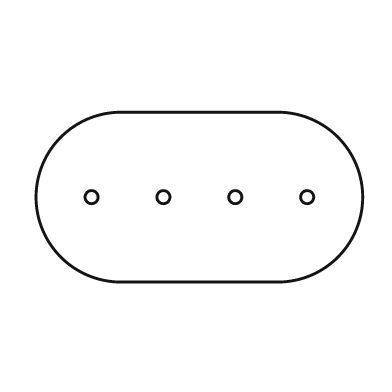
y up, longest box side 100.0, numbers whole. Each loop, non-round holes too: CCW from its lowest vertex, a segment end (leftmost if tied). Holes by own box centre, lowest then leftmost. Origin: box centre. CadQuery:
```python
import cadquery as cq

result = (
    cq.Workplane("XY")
    .moveTo(-24.0, -26.0)
    .lineTo(24.0, -26.0)
    .threePointArc((50.0, 0.0), (24.0, 26.0))
    .lineTo(-24.0, 26.0)
    .threePointArc((-50.0, 0.0), (-24.0, -26.0))
    .close()
    .moveTo(-33.0, 0.0)
    .circle(2.0)
    .moveTo(-11.0, 0.0)
    .circle(2.0)
    .moveTo(11.0, 0.0)
    .circle(2.0)
    .moveTo(33.0, 0.0)
    .circle(2.0)
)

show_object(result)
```